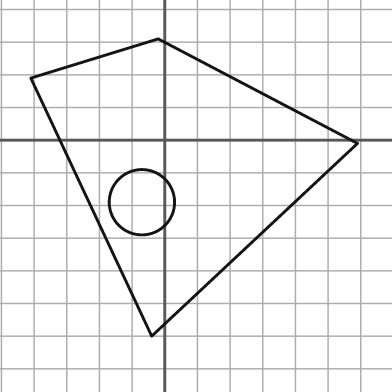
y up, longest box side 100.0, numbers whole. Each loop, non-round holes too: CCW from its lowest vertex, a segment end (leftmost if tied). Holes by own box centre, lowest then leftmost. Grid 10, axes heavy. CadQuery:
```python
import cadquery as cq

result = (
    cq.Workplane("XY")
    .moveTo(-4.0, -60.0)
    .lineTo(59.0, -1.0)
    .lineTo(-2.0, 31.0)
    .lineTo(-41.0, 19.0)
    .close()
    .moveTo(-7.0, -19.0)
    .circle(10.0)
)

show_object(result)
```